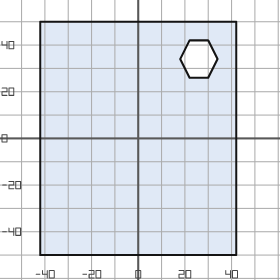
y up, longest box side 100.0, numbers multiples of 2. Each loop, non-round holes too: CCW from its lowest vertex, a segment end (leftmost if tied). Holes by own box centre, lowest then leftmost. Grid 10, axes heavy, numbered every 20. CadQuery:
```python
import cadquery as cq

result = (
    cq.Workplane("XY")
    .moveTo(-42.0, -50.0)
    .lineTo(42.0, -50.0)
    .lineTo(42.0, 50.0)
    .lineTo(-42.0, 50.0)
    .close()
    .moveTo(22.0, 26.0)
    .lineTo(30.0, 26.0)
    .lineTo(34.0, 34.0)
    .lineTo(30.0, 42.0)
    .lineTo(22.0, 42.0)
    .lineTo(18.0, 34.0)
    .close()
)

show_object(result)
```